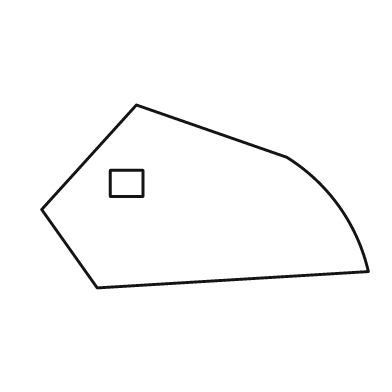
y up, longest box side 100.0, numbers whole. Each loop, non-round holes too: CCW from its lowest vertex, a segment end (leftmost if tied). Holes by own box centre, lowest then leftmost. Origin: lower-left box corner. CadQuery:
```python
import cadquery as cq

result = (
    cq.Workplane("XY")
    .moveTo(17.0, 0.0)
    .lineTo(100.0, 5.0)
    .threePointArc((91.0, 25.0), (75.0, 40.0))
    .lineTo(29.0, 56.0)
    .lineTo(0.0, 24.0)
    .close()
    .moveTo(21.0, 28.0)
    .lineTo(31.0, 28.0)
    .lineTo(31.0, 36.0)
    .lineTo(21.0, 36.0)
    .close()
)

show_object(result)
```